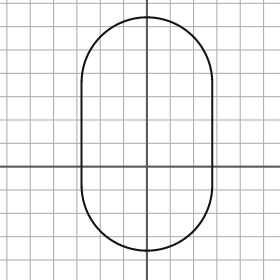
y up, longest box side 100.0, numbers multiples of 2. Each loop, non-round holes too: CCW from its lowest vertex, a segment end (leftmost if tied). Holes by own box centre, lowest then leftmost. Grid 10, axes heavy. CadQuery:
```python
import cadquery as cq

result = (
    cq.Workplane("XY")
    .moveTo(-28.0, -8.0)
    .threePointArc((0.0, -36.0), (28.0, -8.0))
    .lineTo(28.0, 36.0)
    .threePointArc((0.0, 64.0), (-28.0, 36.0))
    .close()
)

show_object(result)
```